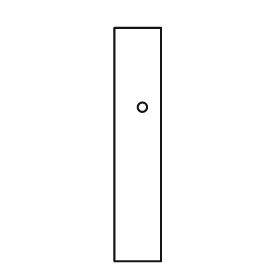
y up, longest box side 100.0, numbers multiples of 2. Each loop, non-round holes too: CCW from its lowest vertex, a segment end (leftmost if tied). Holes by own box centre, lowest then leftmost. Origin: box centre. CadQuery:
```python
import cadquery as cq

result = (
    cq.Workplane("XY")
    .moveTo(-10.0, -50.0)
    .lineTo(10.0, -50.0)
    .lineTo(10.0, 50.0)
    .lineTo(-10.0, 50.0)
    .close()
    .moveTo(2.0, 16.0)
    .circle(2.0)
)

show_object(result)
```